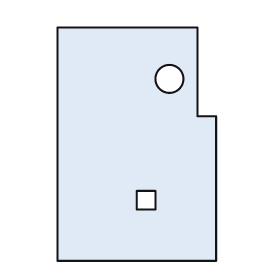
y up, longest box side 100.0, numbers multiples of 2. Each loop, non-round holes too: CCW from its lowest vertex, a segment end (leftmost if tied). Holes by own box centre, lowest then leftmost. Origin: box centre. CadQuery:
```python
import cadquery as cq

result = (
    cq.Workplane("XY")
    .moveTo(-34.0, -50.0)
    .lineTo(34.0, -50.0)
    .lineTo(34.0, 12.0)
    .lineTo(26.0, 12.0)
    .lineTo(26.0, 50.0)
    .lineTo(-34.0, 50.0)
    .close()
    .moveTo(0.0, -28.0)
    .lineTo(8.0, -28.0)
    .lineTo(8.0, -20.0)
    .lineTo(0.0, -20.0)
    .close()
    .moveTo(14.0, 28.0)
    .circle(6.0)
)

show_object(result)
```